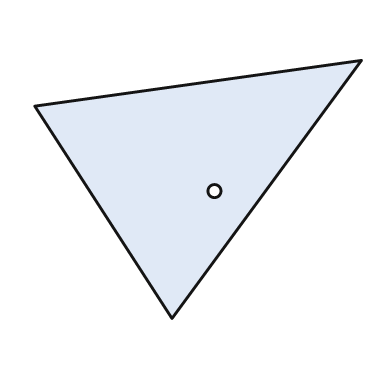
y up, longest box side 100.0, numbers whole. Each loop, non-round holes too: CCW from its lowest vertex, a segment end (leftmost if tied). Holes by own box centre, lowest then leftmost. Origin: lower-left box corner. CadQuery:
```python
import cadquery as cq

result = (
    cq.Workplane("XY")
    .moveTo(42.0, 0.0)
    .lineTo(100.0, 79.0)
    .lineTo(0.0, 65.0)
    .close()
    .moveTo(55.0, 39.0)
    .circle(2.0)
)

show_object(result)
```